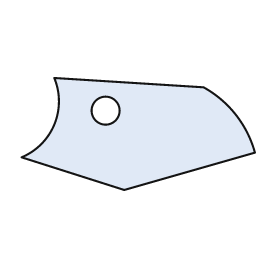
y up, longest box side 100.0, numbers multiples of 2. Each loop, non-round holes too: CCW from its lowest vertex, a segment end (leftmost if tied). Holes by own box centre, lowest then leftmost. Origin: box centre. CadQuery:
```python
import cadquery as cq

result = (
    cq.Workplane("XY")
    .moveTo(-6.0, -24.0)
    .lineTo(50.0, -8.0)
    .threePointArc((42.0, 8.0), (28.0, 20.0))
    .lineTo(-36.0, 24.0)
    .threePointArc((-36.0, 4.0), (-50.0, -10.0))
    .close()
    .moveTo(-14.0, 10.0)
    .circle(6.0)
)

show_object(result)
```